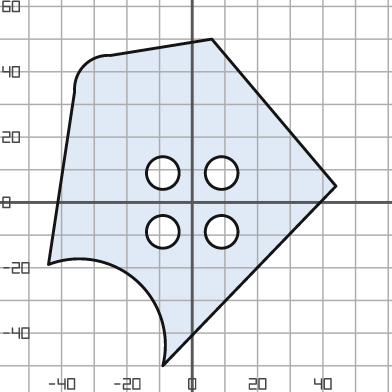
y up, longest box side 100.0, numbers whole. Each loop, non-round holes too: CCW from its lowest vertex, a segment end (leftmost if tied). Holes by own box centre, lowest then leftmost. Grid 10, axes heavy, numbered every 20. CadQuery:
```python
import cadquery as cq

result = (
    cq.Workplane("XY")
    .moveTo(-9.0, -50.0)
    .lineTo(44.0, 5.0)
    .lineTo(6.0, 50.0)
    .lineTo(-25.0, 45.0)
    .threePointArc((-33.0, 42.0), (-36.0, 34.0))
    .lineTo(-44.0, -19.0)
    .threePointArc((-17.0, -24.0), (-9.0, -50.0))
    .close()
    .moveTo(-9.0, -9.0)
    .circle(5.0)
    .moveTo(9.0, -9.0)
    .circle(5.0)
    .moveTo(-9.0, 9.0)
    .circle(5.0)
    .moveTo(9.0, 9.0)
    .circle(5.0)
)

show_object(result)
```